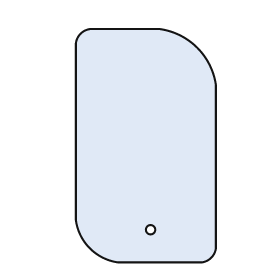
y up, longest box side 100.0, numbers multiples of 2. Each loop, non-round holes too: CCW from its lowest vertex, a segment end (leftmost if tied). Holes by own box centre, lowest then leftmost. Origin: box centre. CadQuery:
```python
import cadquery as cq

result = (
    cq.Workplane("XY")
    .moveTo(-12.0, -50.0)
    .lineTo(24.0, -50.0)
    .threePointArc((28.0, -48.0), (30.0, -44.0))
    .lineTo(30.0, 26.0)
    .threePointArc((22.0, 42.0), (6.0, 50.0))
    .lineTo(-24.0, 50.0)
    .threePointArc((-28.0, 48.0), (-30.0, 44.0))
    .lineTo(-30.0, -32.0)
    .threePointArc((-24.0, -44.0), (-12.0, -50.0))
    .close()
    .moveTo(2.0, -36.0)
    .circle(2.0)
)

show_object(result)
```